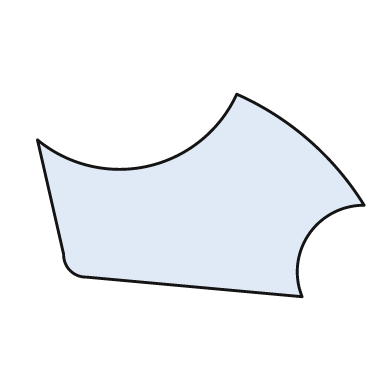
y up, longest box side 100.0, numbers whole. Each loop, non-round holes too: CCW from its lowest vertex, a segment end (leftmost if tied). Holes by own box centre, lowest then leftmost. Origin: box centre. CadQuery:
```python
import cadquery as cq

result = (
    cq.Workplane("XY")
    .moveTo(31.0, -31.0)
    .threePointArc((33.0, -12.0), (50.0, -3.0))
    .threePointArc((33.0, 17.0), (11.0, 31.0))
    .threePointArc((-16.0, 9.0), (-50.0, 17.0))
    .lineTo(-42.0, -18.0)
    .threePointArc((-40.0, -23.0), (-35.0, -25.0))
    .close()
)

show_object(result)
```